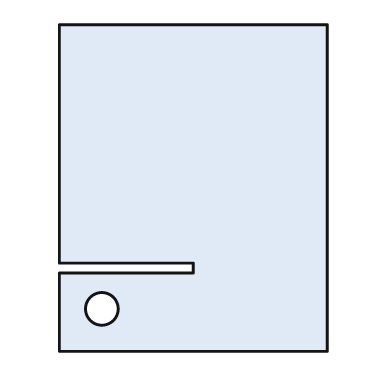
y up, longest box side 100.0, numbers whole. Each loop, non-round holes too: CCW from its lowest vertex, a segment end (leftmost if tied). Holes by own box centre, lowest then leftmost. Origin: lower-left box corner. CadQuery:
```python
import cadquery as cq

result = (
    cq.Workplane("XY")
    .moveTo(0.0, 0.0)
    .lineTo(82.0, 0.0)
    .lineTo(82.0, 100.0)
    .lineTo(0.0, 100.0)
    .lineTo(0.0, 27.0)
    .lineTo(41.0, 27.0)
    .lineTo(41.0, 24.0)
    .lineTo(0.0, 24.0)
    .close()
    .moveTo(13.0, 13.0)
    .circle(5.0)
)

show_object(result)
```